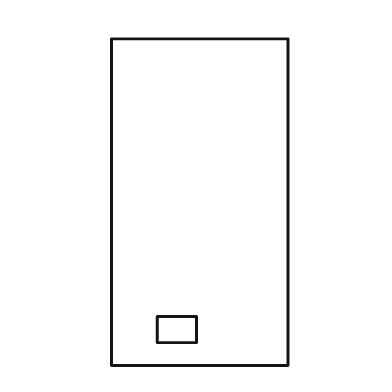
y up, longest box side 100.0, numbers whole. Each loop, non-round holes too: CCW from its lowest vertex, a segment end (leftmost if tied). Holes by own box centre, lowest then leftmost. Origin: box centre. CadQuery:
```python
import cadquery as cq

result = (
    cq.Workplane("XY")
    .moveTo(-27.0, -50.0)
    .lineTo(27.0, -50.0)
    .lineTo(27.0, 50.0)
    .lineTo(-27.0, 50.0)
    .close()
    .moveTo(-13.0, -43.0)
    .lineTo(-1.0, -43.0)
    .lineTo(-1.0, -35.0)
    .lineTo(-13.0, -35.0)
    .close()
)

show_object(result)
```